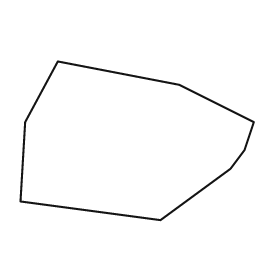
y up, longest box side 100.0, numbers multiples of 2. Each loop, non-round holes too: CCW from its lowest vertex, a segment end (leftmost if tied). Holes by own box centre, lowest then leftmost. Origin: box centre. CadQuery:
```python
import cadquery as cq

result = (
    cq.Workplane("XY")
    .moveTo(10.0, -34.0)
    .lineTo(40.0, -12.0)
    .lineTo(46.0, -4.0)
    .lineTo(50.0, 8.0)
    .lineTo(18.0, 24.0)
    .lineTo(-34.0, 34.0)
    .lineTo(-48.0, 8.0)
    .lineTo(-50.0, -26.0)
    .close()
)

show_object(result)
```